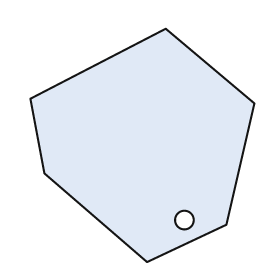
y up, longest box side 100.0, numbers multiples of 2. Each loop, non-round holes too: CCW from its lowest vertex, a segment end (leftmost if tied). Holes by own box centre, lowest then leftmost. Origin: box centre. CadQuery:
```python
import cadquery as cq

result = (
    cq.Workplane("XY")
    .moveTo(2.0, -50.0)
    .lineTo(36.0, -34.0)
    .lineTo(48.0, 18.0)
    .lineTo(10.0, 50.0)
    .lineTo(-48.0, 20.0)
    .lineTo(-42.0, -12.0)
    .close()
    .moveTo(18.0, -32.0)
    .circle(4.0)
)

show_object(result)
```